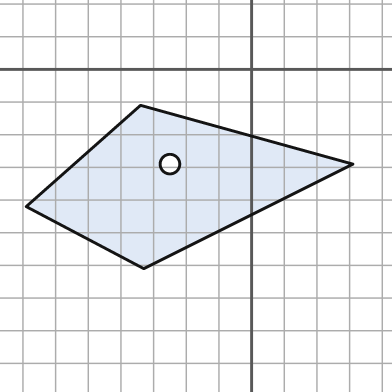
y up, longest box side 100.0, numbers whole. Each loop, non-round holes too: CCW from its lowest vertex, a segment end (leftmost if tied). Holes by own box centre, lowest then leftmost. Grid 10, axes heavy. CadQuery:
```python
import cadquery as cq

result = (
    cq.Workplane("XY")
    .moveTo(-33.0, -61.0)
    .lineTo(31.0, -29.0)
    .lineTo(-34.0, -11.0)
    .lineTo(-69.0, -42.0)
    .close()
    .moveTo(-25.0, -29.0)
    .circle(3.0)
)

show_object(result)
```